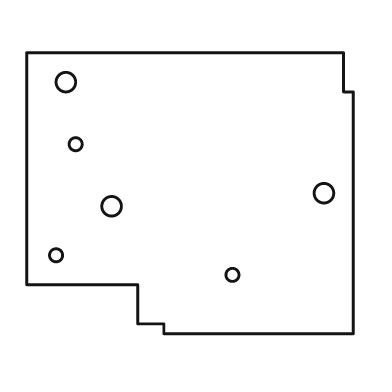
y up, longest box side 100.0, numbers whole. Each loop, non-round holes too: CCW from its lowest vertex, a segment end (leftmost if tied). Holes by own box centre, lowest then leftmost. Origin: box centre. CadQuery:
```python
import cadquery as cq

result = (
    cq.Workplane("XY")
    .moveTo(-8.0, -43.0)
    .lineTo(50.0, -43.0)
    .lineTo(50.0, 31.0)
    .lineTo(47.0, 31.0)
    .lineTo(47.0, 43.0)
    .lineTo(-50.0, 43.0)
    .lineTo(-50.0, -28.0)
    .lineTo(-16.0, -28.0)
    .lineTo(-16.0, -40.0)
    .lineTo(-8.0, -40.0)
    .close()
    .moveTo(13.0, -25.0)
    .circle(2.0)
    .moveTo(-41.0, -19.0)
    .circle(2.0)
    .moveTo(-24.0, -4.0)
    .circle(3.0)
    .moveTo(41.0, 0.0)
    .circle(3.0)
    .moveTo(-35.0, 15.0)
    .circle(2.0)
    .moveTo(-38.0, 34.0)
    .circle(3.0)
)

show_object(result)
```